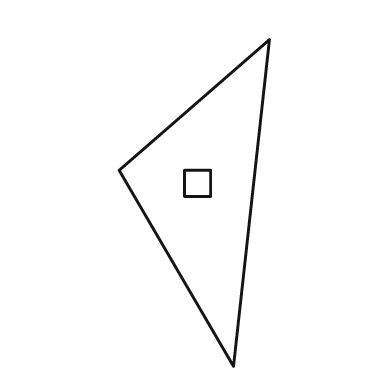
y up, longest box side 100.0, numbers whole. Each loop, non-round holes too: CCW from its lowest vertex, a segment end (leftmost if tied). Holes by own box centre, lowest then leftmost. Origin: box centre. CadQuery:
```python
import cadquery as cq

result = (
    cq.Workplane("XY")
    .moveTo(12.0, -50.0)
    .lineTo(23.0, 50.0)
    .lineTo(-23.0, 10.0)
    .close()
    .moveTo(-3.0, 2.0)
    .lineTo(5.0, 2.0)
    .lineTo(5.0, 10.0)
    .lineTo(-3.0, 10.0)
    .close()
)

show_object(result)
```